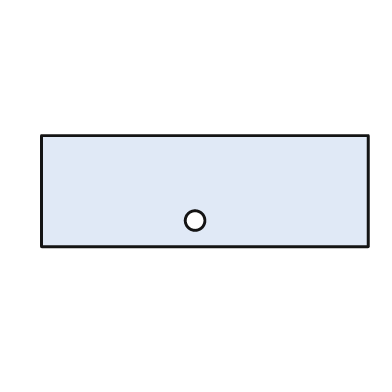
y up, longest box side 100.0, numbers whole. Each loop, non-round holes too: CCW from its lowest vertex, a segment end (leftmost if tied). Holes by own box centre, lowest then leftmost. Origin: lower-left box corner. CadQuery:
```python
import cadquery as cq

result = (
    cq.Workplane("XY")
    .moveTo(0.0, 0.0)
    .lineTo(100.0, 0.0)
    .lineTo(100.0, 34.0)
    .lineTo(0.0, 34.0)
    .close()
    .moveTo(47.0, 8.0)
    .circle(3.0)
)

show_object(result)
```